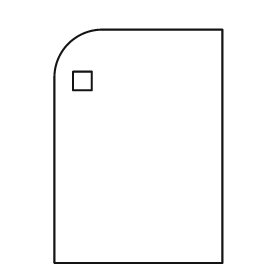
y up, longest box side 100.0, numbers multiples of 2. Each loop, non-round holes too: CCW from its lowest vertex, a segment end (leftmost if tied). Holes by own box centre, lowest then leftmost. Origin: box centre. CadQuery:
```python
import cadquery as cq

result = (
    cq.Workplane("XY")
    .moveTo(-36.0, -50.0)
    .lineTo(36.0, -50.0)
    .lineTo(36.0, 50.0)
    .lineTo(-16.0, 50.0)
    .threePointArc((-30.0, 44.0), (-36.0, 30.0))
    .close()
    .moveTo(-28.0, 24.0)
    .lineTo(-20.0, 24.0)
    .lineTo(-20.0, 32.0)
    .lineTo(-28.0, 32.0)
    .close()
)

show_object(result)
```